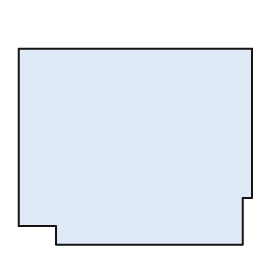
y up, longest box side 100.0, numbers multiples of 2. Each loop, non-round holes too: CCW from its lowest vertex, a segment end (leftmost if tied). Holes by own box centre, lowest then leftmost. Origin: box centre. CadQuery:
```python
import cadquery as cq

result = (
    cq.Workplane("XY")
    .moveTo(-34.0, -42.0)
    .lineTo(46.0, -42.0)
    .lineTo(46.0, -22.0)
    .lineTo(50.0, -22.0)
    .lineTo(50.0, 42.0)
    .lineTo(-50.0, 42.0)
    .lineTo(-50.0, -34.0)
    .lineTo(-34.0, -34.0)
    .close()
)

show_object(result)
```